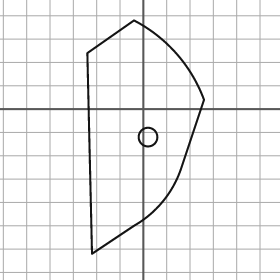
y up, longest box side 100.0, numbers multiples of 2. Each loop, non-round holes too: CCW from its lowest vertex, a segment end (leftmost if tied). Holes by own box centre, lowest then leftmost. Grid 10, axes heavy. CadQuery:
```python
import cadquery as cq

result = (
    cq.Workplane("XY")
    .moveTo(-22.0, -62.0)
    .lineTo(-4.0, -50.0)
    .threePointArc((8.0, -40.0), (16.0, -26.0))
    .lineTo(26.0, 4.0)
    .threePointArc((14.0, 24.0), (-4.0, 38.0))
    .lineTo(-24.0, 24.0)
    .close()
    .moveTo(2.0, -12.0)
    .circle(4.0)
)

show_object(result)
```